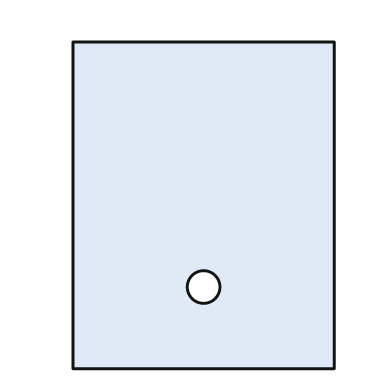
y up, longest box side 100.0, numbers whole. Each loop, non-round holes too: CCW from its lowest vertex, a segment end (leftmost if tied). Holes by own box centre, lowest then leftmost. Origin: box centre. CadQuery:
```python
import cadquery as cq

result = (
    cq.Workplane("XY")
    .moveTo(-40.0, -50.0)
    .lineTo(40.0, -50.0)
    .lineTo(40.0, 50.0)
    .lineTo(-40.0, 50.0)
    .close()
    .moveTo(0.0, -25.0)
    .circle(5.0)
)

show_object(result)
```